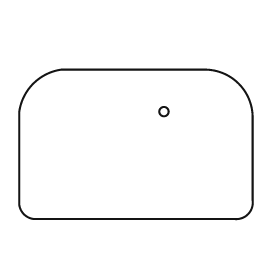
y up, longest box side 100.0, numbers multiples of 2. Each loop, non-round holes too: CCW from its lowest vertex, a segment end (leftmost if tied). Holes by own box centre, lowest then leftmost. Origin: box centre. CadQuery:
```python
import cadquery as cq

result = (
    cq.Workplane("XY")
    .moveTo(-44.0, -32.0)
    .lineTo(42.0, -32.0)
    .threePointArc((48.0, -30.0), (50.0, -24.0))
    .lineTo(50.0, 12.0)
    .threePointArc((44.0, 26.0), (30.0, 32.0))
    .lineTo(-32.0, 32.0)
    .threePointArc((-44.0, 26.0), (-50.0, 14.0))
    .lineTo(-50.0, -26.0)
    .threePointArc((-48.0, -30.0), (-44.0, -32.0))
    .close()
    .moveTo(12.0, 14.0)
    .circle(2.0)
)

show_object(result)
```